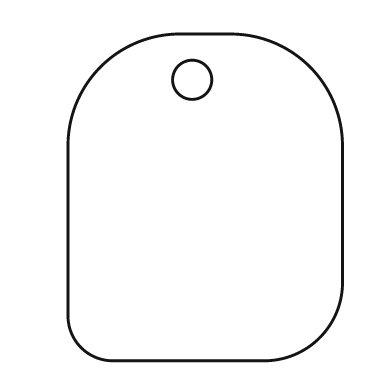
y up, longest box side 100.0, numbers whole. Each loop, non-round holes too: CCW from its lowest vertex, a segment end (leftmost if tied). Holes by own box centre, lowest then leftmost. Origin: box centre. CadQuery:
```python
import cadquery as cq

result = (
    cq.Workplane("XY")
    .moveTo(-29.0, -50.0)
    .lineTo(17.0, -50.0)
    .threePointArc((35.0, -43.0), (42.0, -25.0))
    .lineTo(42.0, 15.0)
    .threePointArc((32.0, 40.0), (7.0, 50.0))
    .lineTo(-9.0, 50.0)
    .threePointArc((-32.0, 40.0), (-42.0, 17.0))
    .lineTo(-42.0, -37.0)
    .threePointArc((-38.0, -46.0), (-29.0, -50.0))
    .close()
    .moveTo(-4.0, 36.0)
    .circle(6.0)
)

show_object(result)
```